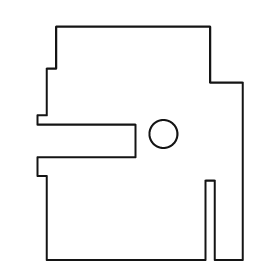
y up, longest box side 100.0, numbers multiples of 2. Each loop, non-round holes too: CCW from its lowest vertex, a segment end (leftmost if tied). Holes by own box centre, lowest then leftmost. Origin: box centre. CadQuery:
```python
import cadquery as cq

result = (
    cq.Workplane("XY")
    .moveTo(-40.0, -50.0)
    .lineTo(28.0, -50.0)
    .lineTo(28.0, -16.0)
    .lineTo(32.0, -16.0)
    .lineTo(32.0, -50.0)
    .lineTo(44.0, -50.0)
    .lineTo(44.0, 26.0)
    .lineTo(30.0, 26.0)
    .lineTo(30.0, 50.0)
    .lineTo(-36.0, 50.0)
    .lineTo(-36.0, 32.0)
    .lineTo(-40.0, 32.0)
    .lineTo(-40.0, 12.0)
    .lineTo(-44.0, 12.0)
    .lineTo(-44.0, 8.0)
    .lineTo(-2.0, 8.0)
    .lineTo(-2.0, -6.0)
    .lineTo(-44.0, -6.0)
    .lineTo(-44.0, -14.0)
    .lineTo(-40.0, -14.0)
    .close()
    .moveTo(10.0, 4.0)
    .circle(6.0)
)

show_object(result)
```